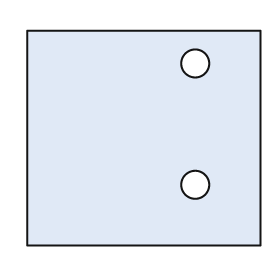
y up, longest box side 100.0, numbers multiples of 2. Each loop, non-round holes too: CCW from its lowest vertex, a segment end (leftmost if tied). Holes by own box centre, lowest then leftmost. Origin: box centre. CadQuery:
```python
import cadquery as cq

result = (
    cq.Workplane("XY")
    .moveTo(-50.0, -46.0)
    .lineTo(50.0, -46.0)
    .lineTo(50.0, 46.0)
    .lineTo(-50.0, 46.0)
    .close()
    .moveTo(22.0, -20.0)
    .circle(6.0)
    .moveTo(22.0, 32.0)
    .circle(6.0)
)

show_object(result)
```